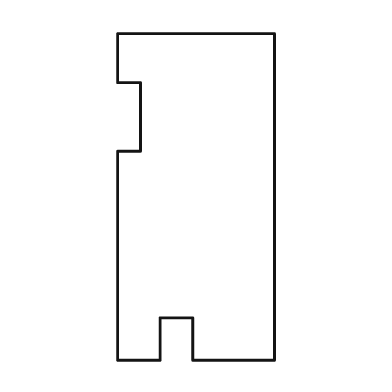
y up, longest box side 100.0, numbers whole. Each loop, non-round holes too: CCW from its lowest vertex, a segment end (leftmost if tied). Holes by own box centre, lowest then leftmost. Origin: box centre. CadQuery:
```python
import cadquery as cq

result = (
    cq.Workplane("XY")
    .moveTo(-24.0, -50.0)
    .lineTo(-11.0, -50.0)
    .lineTo(-11.0, -37.0)
    .lineTo(-1.0, -37.0)
    .lineTo(-1.0, -50.0)
    .lineTo(24.0, -50.0)
    .lineTo(24.0, 50.0)
    .lineTo(-24.0, 50.0)
    .lineTo(-24.0, 35.0)
    .lineTo(-17.0, 35.0)
    .lineTo(-17.0, 14.0)
    .lineTo(-24.0, 14.0)
    .close()
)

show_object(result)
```